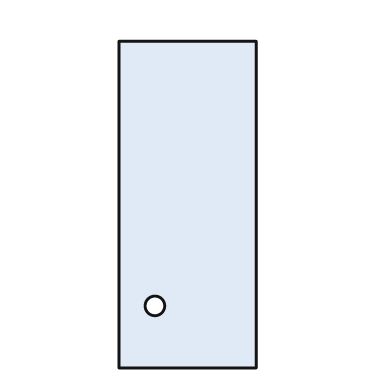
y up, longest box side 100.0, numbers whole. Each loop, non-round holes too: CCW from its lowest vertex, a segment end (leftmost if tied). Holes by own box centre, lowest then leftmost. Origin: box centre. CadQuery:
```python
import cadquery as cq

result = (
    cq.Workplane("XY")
    .moveTo(-21.0, -50.0)
    .lineTo(21.0, -50.0)
    .lineTo(21.0, 50.0)
    .lineTo(-21.0, 50.0)
    .close()
    .moveTo(-10.0, -31.0)
    .circle(3.0)
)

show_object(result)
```